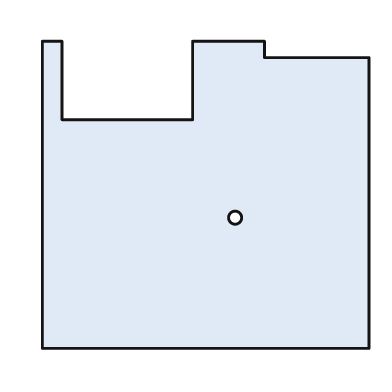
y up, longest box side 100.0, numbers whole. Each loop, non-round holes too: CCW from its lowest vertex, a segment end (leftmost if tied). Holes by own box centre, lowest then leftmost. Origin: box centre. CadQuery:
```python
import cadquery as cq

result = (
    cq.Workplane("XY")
    .moveTo(-50.0, -47.0)
    .lineTo(50.0, -47.0)
    .lineTo(50.0, 42.0)
    .lineTo(18.0, 42.0)
    .lineTo(18.0, 47.0)
    .lineTo(-4.0, 47.0)
    .lineTo(-4.0, 23.0)
    .lineTo(-44.0, 23.0)
    .lineTo(-44.0, 47.0)
    .lineTo(-50.0, 47.0)
    .close()
    .moveTo(9.0, -7.0)
    .circle(2.0)
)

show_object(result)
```